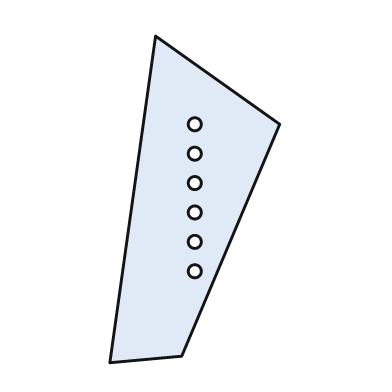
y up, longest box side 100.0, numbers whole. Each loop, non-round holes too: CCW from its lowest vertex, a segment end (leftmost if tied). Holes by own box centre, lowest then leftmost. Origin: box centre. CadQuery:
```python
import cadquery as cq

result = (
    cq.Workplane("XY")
    .moveTo(-26.0, -50.0)
    .lineTo(-4.0, -48.0)
    .lineTo(26.0, 23.0)
    .lineTo(-12.0, 50.0)
    .close()
    .moveTo(0.0, -22.0)
    .circle(2.0)
    .moveTo(0.0, -13.0)
    .circle(2.0)
    .moveTo(0.0, -4.0)
    .circle(2.0)
    .moveTo(0.0, 5.0)
    .circle(2.0)
    .moveTo(0.0, 14.0)
    .circle(2.0)
    .moveTo(0.0, 23.0)
    .circle(2.0)
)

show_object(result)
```